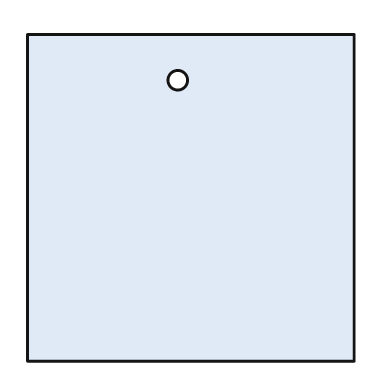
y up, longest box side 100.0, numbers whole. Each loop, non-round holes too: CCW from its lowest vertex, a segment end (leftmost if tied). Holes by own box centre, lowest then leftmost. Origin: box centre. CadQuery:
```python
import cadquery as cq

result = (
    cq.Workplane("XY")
    .moveTo(-50.0, -50.0)
    .lineTo(50.0, -50.0)
    .lineTo(50.0, 50.0)
    .lineTo(-50.0, 50.0)
    .close()
    .moveTo(-4.0, 36.0)
    .circle(3.0)
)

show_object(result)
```